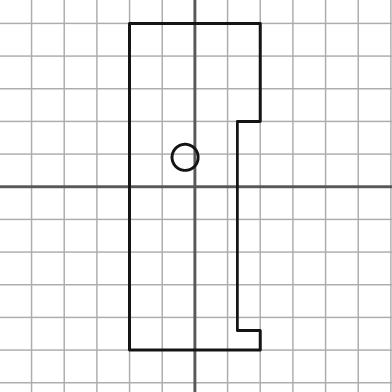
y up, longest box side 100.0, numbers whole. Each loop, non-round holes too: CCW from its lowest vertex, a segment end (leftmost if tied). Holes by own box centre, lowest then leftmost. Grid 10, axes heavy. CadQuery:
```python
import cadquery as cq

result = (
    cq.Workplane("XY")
    .moveTo(-20.0, -50.0)
    .lineTo(20.0, -50.0)
    .lineTo(20.0, -44.0)
    .lineTo(13.0, -44.0)
    .lineTo(13.0, 20.0)
    .lineTo(20.0, 20.0)
    .lineTo(20.0, 50.0)
    .lineTo(-20.0, 50.0)
    .close()
    .moveTo(-3.0, 9.0)
    .circle(4.0)
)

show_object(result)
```